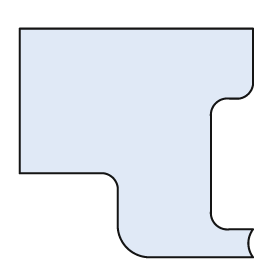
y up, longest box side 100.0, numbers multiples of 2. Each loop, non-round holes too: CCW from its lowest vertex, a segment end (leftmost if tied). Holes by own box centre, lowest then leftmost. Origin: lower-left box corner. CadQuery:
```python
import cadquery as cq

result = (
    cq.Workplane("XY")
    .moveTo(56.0, 0.0)
    .lineTo(100.0, 0.0)
    .threePointArc((98.0, 6.0), (100.0, 12.0))
    .lineTo(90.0, 12.0)
    .threePointArc((84.0, 14.0), (82.0, 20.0))
    .lineTo(82.0, 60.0)
    .threePointArc((84.0, 66.0), (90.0, 68.0))
    .lineTo(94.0, 68.0)
    .threePointArc((98.0, 70.0), (100.0, 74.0))
    .lineTo(100.0, 98.0)
    .lineTo(0.0, 98.0)
    .lineTo(0.0, 36.0)
    .lineTo(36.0, 36.0)
    .threePointArc((40.0, 34.0), (42.0, 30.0))
    .lineTo(42.0, 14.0)
    .threePointArc((46.0, 4.0), (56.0, 0.0))
    .close()
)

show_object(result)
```